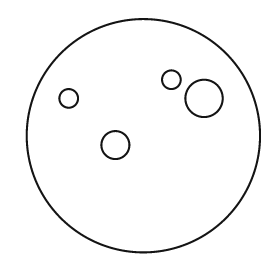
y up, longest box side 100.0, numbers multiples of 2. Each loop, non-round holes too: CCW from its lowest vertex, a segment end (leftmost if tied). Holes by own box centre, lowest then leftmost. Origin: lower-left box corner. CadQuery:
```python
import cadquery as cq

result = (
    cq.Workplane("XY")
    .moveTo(50.0, 50.0)
    .circle(50.0)
    .moveTo(38.0, 46.0)
    .circle(6.0)
    .moveTo(18.0, 66.0)
    .circle(4.0)
    .moveTo(76.0, 66.0)
    .circle(8.0)
    .moveTo(62.0, 74.0)
    .circle(4.0)
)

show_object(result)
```